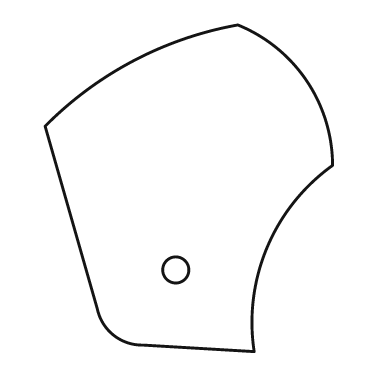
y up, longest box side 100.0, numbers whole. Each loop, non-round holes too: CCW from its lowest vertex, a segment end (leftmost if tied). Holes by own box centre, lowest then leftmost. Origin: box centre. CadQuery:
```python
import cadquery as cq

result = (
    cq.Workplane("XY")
    .moveTo(20.0, -50.0)
    .threePointArc((24.0, -18.0), (44.0, 7.0))
    .threePointArc((36.0, 33.0), (15.0, 50.0))
    .threePointArc((-17.0, 39.0), (-44.0, 19.0))
    .lineTo(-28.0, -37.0)
    .threePointArc((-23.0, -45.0), (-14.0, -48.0))
    .close()
    .moveTo(-4.0, -25.0)
    .circle(4.0)
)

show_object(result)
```